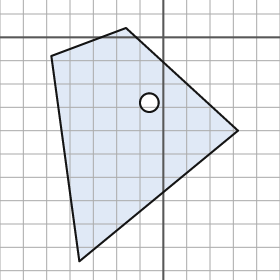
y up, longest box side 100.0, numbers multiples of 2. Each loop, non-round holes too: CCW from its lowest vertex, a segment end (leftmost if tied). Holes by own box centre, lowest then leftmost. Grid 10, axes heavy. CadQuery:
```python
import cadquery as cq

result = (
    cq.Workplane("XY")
    .moveTo(-36.0, -96.0)
    .lineTo(32.0, -40.0)
    .lineTo(-16.0, 4.0)
    .lineTo(-48.0, -8.0)
    .close()
    .moveTo(-6.0, -28.0)
    .circle(4.0)
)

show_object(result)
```